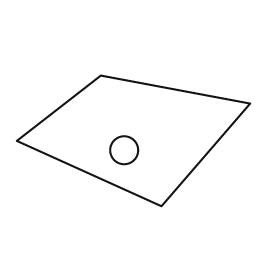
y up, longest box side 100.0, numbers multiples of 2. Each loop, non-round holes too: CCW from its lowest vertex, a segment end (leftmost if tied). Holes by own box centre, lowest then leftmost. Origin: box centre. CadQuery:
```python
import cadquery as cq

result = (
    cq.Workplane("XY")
    .moveTo(12.0, -28.0)
    .lineTo(50.0, 16.0)
    .lineTo(-14.0, 28.0)
    .lineTo(-50.0, 0.0)
    .close()
    .moveTo(-4.0, -4.0)
    .circle(6.0)
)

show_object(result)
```